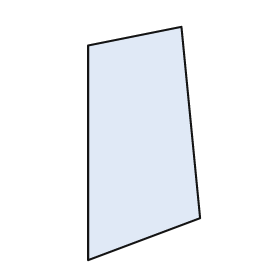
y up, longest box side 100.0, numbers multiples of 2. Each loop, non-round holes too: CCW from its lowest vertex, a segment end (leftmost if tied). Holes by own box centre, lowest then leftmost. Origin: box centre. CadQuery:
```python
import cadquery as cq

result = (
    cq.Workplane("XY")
    .moveTo(-24.0, -50.0)
    .lineTo(24.0, -32.0)
    .lineTo(16.0, 50.0)
    .lineTo(-24.0, 42.0)
    .close()
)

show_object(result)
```